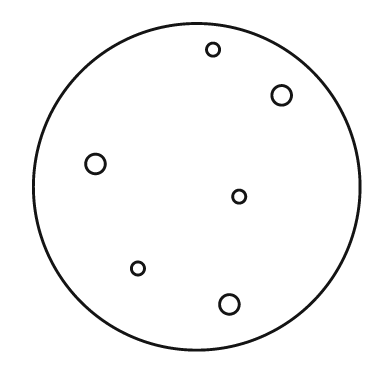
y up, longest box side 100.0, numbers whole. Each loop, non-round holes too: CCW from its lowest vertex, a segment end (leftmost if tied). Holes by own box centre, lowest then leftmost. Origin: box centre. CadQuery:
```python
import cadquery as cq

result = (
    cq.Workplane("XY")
    .moveTo(0.0, 0.0)
    .circle(50.0)
    .moveTo(10.0, -36.0)
    .circle(3.0)
    .moveTo(-18.0, -25.0)
    .circle(2.0)
    .moveTo(13.0, -3.0)
    .circle(2.0)
    .moveTo(-31.0, 7.0)
    .circle(3.0)
    .moveTo(26.0, 28.0)
    .circle(3.0)
    .moveTo(5.0, 42.0)
    .circle(2.0)
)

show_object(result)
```